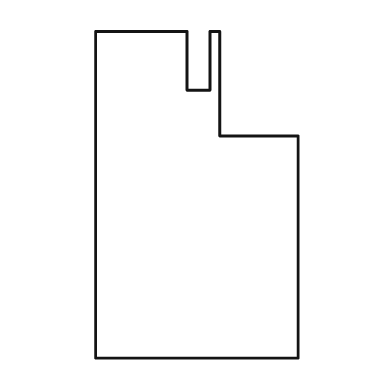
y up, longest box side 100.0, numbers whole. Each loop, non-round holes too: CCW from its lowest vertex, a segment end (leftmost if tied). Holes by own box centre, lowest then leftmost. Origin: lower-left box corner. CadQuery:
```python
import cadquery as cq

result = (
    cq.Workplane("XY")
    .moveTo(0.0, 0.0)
    .lineTo(62.0, 0.0)
    .lineTo(62.0, 68.0)
    .lineTo(38.0, 68.0)
    .lineTo(38.0, 100.0)
    .lineTo(35.0, 100.0)
    .lineTo(35.0, 82.0)
    .lineTo(28.0, 82.0)
    .lineTo(28.0, 100.0)
    .lineTo(0.0, 100.0)
    .close()
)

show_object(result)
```